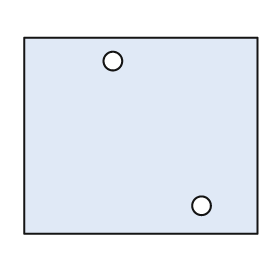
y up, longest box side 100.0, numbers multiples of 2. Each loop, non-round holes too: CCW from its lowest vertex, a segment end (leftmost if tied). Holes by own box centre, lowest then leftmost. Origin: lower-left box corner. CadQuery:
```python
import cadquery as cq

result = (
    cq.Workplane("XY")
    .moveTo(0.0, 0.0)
    .lineTo(100.0, 0.0)
    .lineTo(100.0, 84.0)
    .lineTo(0.0, 84.0)
    .close()
    .moveTo(76.0, 12.0)
    .circle(4.0)
    .moveTo(38.0, 74.0)
    .circle(4.0)
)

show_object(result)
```